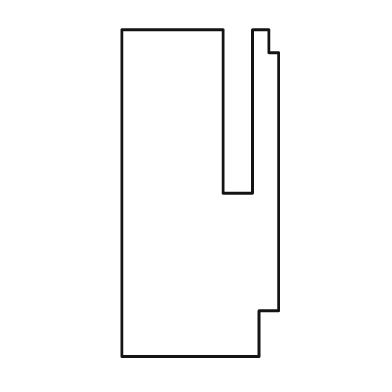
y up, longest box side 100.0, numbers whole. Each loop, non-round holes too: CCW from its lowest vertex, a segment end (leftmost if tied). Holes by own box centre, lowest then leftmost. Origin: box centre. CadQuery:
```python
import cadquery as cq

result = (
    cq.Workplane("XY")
    .moveTo(-24.0, -50.0)
    .lineTo(18.0, -50.0)
    .lineTo(18.0, -36.0)
    .lineTo(24.0, -36.0)
    .lineTo(24.0, 43.0)
    .lineTo(21.0, 43.0)
    .lineTo(21.0, 50.0)
    .lineTo(16.0, 50.0)
    .lineTo(16.0, 0.0)
    .lineTo(7.0, 0.0)
    .lineTo(7.0, 50.0)
    .lineTo(-24.0, 50.0)
    .close()
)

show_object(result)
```